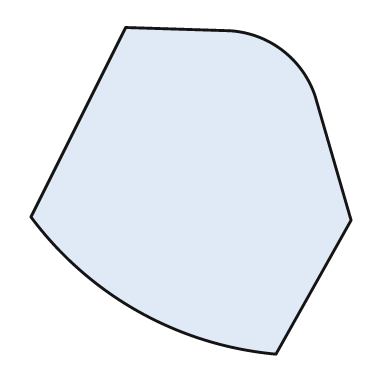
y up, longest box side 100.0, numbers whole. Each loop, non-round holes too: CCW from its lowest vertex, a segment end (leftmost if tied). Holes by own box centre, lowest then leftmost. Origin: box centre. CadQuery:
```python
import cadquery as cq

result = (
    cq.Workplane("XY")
    .moveTo(26.0, -50.0)
    .lineTo(49.0, -9.0)
    .lineTo(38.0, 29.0)
    .threePointArc((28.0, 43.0), (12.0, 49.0))
    .lineTo(-20.0, 50.0)
    .lineTo(-49.0, -8.0)
    .threePointArc((-16.0, -37.0), (26.0, -50.0))
    .close()
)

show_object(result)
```